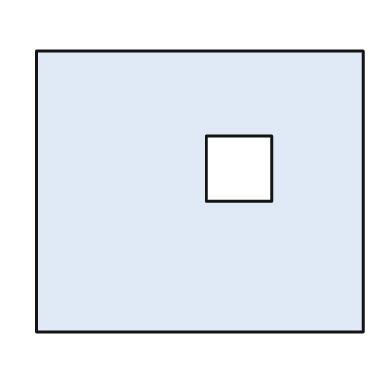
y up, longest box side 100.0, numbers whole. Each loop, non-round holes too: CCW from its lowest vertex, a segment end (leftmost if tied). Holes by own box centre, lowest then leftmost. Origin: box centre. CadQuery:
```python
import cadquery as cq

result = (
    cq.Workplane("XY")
    .moveTo(-50.0, -43.0)
    .lineTo(50.0, -43.0)
    .lineTo(50.0, 43.0)
    .lineTo(-50.0, 43.0)
    .close()
    .moveTo(2.0, -3.0)
    .lineTo(22.0, -3.0)
    .lineTo(22.0, 17.0)
    .lineTo(2.0, 17.0)
    .close()
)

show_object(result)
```